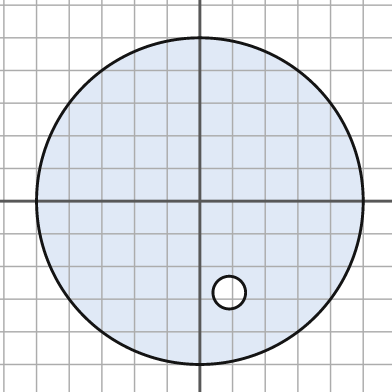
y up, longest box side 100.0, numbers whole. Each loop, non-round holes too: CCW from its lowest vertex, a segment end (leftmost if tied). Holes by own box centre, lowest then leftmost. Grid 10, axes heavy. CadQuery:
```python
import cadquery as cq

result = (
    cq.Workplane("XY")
    .moveTo(0.0, 0.0)
    .circle(50.0)
    .moveTo(9.0, -28.0)
    .circle(5.0)
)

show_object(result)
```